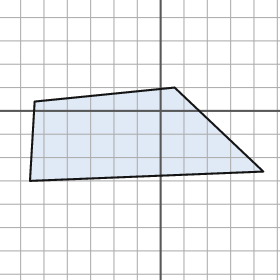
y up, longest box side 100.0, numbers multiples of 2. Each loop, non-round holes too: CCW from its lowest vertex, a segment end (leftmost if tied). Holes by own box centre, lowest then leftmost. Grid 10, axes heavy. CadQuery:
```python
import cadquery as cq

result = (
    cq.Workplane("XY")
    .moveTo(-56.0, -30.0)
    .lineTo(44.0, -26.0)
    .lineTo(6.0, 10.0)
    .lineTo(-54.0, 4.0)
    .close()
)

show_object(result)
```